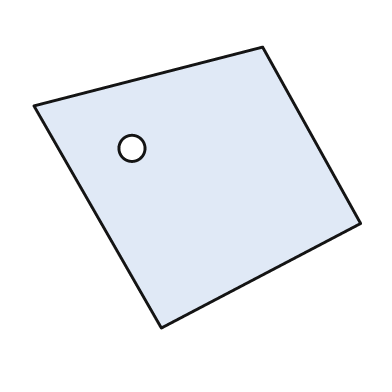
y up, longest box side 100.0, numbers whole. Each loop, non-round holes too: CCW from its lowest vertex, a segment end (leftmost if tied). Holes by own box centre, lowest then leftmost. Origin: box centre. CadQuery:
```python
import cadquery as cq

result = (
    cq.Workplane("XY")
    .moveTo(-11.0, -43.0)
    .lineTo(50.0, -11.0)
    .lineTo(20.0, 43.0)
    .lineTo(-50.0, 25.0)
    .close()
    .moveTo(-20.0, 12.0)
    .circle(4.0)
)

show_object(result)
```